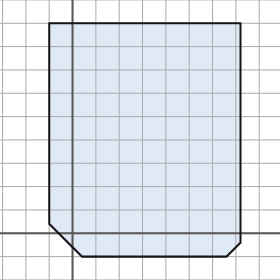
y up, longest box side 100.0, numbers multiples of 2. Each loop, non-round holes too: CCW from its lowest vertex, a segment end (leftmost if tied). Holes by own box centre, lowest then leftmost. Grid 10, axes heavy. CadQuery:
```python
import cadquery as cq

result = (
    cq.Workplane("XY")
    .moveTo(4.0, -10.0)
    .lineTo(66.0, -10.0)
    .lineTo(72.0, -4.0)
    .lineTo(72.0, 90.0)
    .lineTo(-10.0, 90.0)
    .lineTo(-10.0, 4.0)
    .close()
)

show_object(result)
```